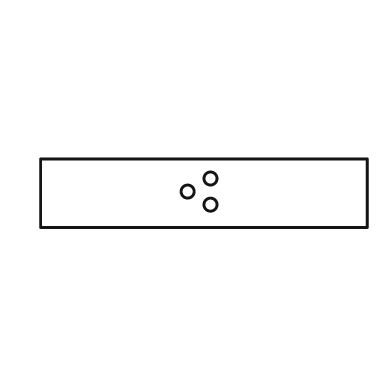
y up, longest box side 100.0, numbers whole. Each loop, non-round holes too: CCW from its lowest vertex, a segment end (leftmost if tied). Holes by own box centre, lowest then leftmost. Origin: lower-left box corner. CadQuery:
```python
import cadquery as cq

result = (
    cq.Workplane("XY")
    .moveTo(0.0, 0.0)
    .lineTo(100.0, 0.0)
    .lineTo(100.0, 21.0)
    .lineTo(0.0, 21.0)
    .close()
    .moveTo(52.0, 7.0)
    .circle(2.0)
    .moveTo(45.0, 11.0)
    .circle(2.0)
    .moveTo(52.0, 15.0)
    .circle(2.0)
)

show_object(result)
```